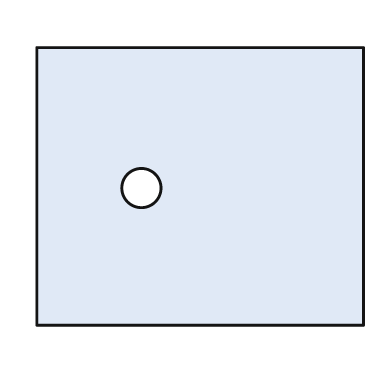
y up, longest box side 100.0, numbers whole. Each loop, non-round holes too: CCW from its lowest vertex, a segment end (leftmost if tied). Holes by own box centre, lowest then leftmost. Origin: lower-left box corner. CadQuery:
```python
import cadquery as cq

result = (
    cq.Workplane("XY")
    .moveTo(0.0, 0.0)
    .lineTo(100.0, 0.0)
    .lineTo(100.0, 85.0)
    .lineTo(0.0, 85.0)
    .close()
    .moveTo(32.0, 42.0)
    .circle(6.0)
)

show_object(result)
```